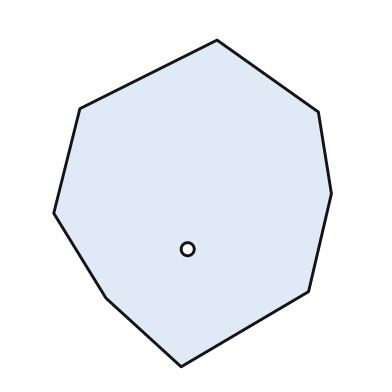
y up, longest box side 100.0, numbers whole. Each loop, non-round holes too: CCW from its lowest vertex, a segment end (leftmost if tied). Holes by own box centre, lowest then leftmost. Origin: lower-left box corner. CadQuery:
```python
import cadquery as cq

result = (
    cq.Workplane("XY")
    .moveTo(39.0, 0.0)
    .lineTo(78.0, 23.0)
    .lineTo(85.0, 53.0)
    .lineTo(81.0, 78.0)
    .lineTo(50.0, 100.0)
    .lineTo(8.0, 79.0)
    .lineTo(0.0, 47.0)
    .lineTo(16.0, 21.0)
    .close()
    .moveTo(41.0, 36.0)
    .circle(2.0)
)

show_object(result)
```